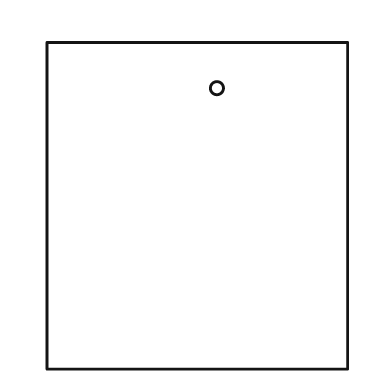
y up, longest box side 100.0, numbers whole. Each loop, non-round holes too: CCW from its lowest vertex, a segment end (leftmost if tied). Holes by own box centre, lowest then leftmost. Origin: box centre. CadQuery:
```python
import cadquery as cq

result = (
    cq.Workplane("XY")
    .moveTo(-46.0, -50.0)
    .lineTo(46.0, -50.0)
    .lineTo(46.0, 50.0)
    .lineTo(-46.0, 50.0)
    .close()
    .moveTo(6.0, 36.0)
    .circle(2.0)
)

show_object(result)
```